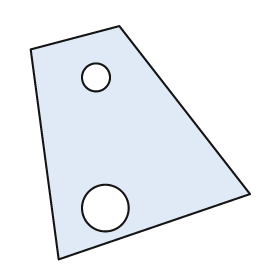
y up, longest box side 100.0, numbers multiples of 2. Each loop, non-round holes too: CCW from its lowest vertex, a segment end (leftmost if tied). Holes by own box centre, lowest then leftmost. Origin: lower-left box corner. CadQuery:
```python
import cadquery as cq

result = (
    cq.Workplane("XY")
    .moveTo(12.0, 0.0)
    .lineTo(94.0, 28.0)
    .lineTo(38.0, 100.0)
    .lineTo(0.0, 90.0)
    .close()
    .moveTo(32.0, 22.0)
    .circle(10.0)
    .moveTo(28.0, 78.0)
    .circle(6.0)
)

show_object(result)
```